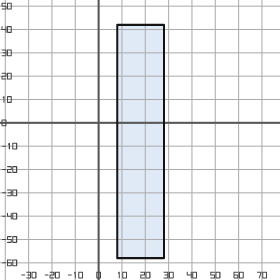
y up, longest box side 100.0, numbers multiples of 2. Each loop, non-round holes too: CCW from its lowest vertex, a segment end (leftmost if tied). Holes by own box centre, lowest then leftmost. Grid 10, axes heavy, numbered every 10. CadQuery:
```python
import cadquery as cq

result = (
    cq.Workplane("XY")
    .moveTo(8.0, -58.0)
    .lineTo(28.0, -58.0)
    .lineTo(28.0, 42.0)
    .lineTo(8.0, 42.0)
    .close()
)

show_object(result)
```